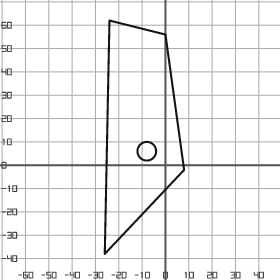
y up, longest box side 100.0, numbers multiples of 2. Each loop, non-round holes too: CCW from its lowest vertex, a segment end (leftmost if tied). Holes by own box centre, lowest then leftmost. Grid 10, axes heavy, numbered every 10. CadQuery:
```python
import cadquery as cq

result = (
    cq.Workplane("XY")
    .moveTo(-26.0, -38.0)
    .lineTo(8.0, -2.0)
    .lineTo(0.0, 56.0)
    .lineTo(-24.0, 62.0)
    .close()
    .moveTo(-8.0, 6.0)
    .circle(4.0)
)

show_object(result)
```